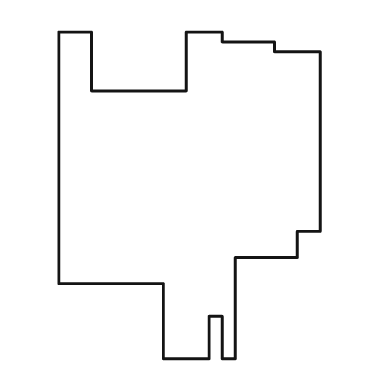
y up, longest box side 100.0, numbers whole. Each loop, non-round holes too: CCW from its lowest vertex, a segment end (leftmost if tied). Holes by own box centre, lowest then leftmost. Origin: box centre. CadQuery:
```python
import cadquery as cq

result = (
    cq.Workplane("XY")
    .moveTo(-8.0, -50.0)
    .lineTo(6.0, -50.0)
    .lineTo(6.0, -37.0)
    .lineTo(10.0, -37.0)
    .lineTo(10.0, -50.0)
    .lineTo(14.0, -50.0)
    .lineTo(14.0, -19.0)
    .lineTo(33.0, -19.0)
    .lineTo(33.0, -11.0)
    .lineTo(40.0, -11.0)
    .lineTo(40.0, 44.0)
    .lineTo(26.0, 44.0)
    .lineTo(26.0, 47.0)
    .lineTo(10.0, 47.0)
    .lineTo(10.0, 50.0)
    .lineTo(-1.0, 50.0)
    .lineTo(-1.0, 32.0)
    .lineTo(-30.0, 32.0)
    .lineTo(-30.0, 50.0)
    .lineTo(-40.0, 50.0)
    .lineTo(-40.0, -27.0)
    .lineTo(-8.0, -27.0)
    .close()
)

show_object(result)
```